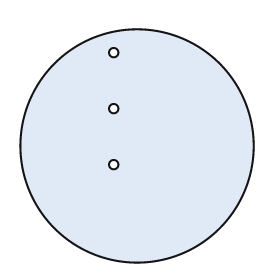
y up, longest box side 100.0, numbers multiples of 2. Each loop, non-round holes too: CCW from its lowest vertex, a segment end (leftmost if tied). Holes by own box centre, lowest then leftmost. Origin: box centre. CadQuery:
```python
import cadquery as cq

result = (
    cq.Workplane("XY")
    .moveTo(0.0, 0.0)
    .circle(50.0)
    .moveTo(-10.0, -8.0)
    .circle(2.0)
    .moveTo(-10.0, 16.0)
    .circle(2.0)
    .moveTo(-10.0, 40.0)
    .circle(2.0)
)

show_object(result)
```